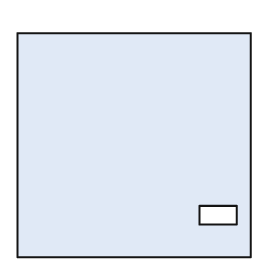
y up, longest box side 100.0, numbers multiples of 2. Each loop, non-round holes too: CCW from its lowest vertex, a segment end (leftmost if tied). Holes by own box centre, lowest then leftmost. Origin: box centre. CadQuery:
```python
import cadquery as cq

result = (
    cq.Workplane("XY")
    .moveTo(-50.0, -48.0)
    .lineTo(50.0, -48.0)
    .lineTo(50.0, 48.0)
    .lineTo(-50.0, 48.0)
    .close()
    .moveTo(28.0, -34.0)
    .lineTo(44.0, -34.0)
    .lineTo(44.0, -26.0)
    .lineTo(28.0, -26.0)
    .close()
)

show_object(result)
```